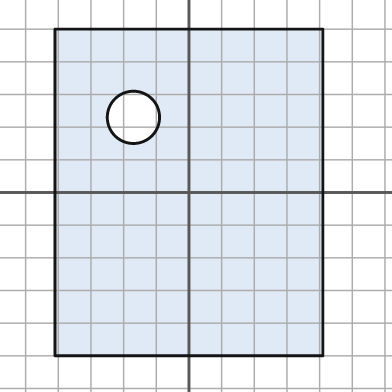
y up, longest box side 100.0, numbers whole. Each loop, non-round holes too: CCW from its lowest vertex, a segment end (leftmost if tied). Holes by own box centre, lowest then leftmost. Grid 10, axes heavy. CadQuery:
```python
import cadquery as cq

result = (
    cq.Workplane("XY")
    .moveTo(-41.0, -50.0)
    .lineTo(41.0, -50.0)
    .lineTo(41.0, 50.0)
    .lineTo(-41.0, 50.0)
    .close()
    .moveTo(-17.0, 23.0)
    .circle(8.0)
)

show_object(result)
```